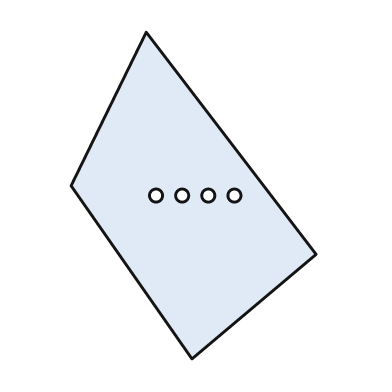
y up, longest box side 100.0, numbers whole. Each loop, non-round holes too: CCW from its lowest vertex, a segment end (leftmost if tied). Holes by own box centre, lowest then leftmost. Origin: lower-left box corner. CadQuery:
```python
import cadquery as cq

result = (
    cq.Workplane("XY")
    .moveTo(37.0, 0.0)
    .lineTo(75.0, 32.0)
    .lineTo(23.0, 100.0)
    .lineTo(0.0, 53.0)
    .close()
    .moveTo(26.0, 50.0)
    .circle(2.0)
    .moveTo(34.0, 50.0)
    .circle(2.0)
    .moveTo(42.0, 50.0)
    .circle(2.0)
    .moveTo(50.0, 50.0)
    .circle(2.0)
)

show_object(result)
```